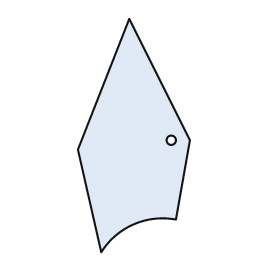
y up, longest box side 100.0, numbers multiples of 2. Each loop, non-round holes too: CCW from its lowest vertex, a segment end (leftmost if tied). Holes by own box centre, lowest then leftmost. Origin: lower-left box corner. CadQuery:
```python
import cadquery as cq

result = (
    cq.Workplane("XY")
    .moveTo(10.0, 0.0)
    .threePointArc((24.0, 12.0), (42.0, 14.0))
    .lineTo(48.0, 48.0)
    .lineTo(22.0, 100.0)
    .lineTo(0.0, 44.0)
    .close()
    .moveTo(40.0, 48.0)
    .circle(2.0)
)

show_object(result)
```